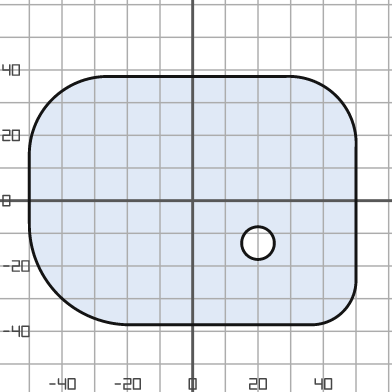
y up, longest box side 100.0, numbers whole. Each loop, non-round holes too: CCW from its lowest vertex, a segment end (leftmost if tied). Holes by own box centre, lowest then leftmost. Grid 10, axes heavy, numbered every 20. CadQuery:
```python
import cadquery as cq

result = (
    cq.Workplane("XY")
    .moveTo(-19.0, -38.0)
    .lineTo(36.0, -38.0)
    .threePointArc((46.0, -34.0), (50.0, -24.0))
    .lineTo(50.0, 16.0)
    .threePointArc((44.0, 32.0), (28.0, 38.0))
    .lineTo(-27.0, 38.0)
    .threePointArc((-43.0, 31.0), (-50.0, 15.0))
    .lineTo(-50.0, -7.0)
    .threePointArc((-41.0, -29.0), (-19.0, -38.0))
    .close()
    .moveTo(20.0, -13.0)
    .circle(5.0)
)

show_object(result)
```